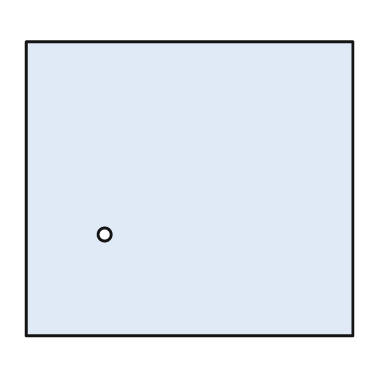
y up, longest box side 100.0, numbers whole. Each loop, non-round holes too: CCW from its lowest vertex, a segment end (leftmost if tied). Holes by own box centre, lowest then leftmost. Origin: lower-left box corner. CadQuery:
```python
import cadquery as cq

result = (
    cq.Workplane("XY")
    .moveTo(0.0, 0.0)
    .lineTo(100.0, 0.0)
    .lineTo(100.0, 90.0)
    .lineTo(0.0, 90.0)
    .close()
    .moveTo(24.0, 31.0)
    .circle(2.0)
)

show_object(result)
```